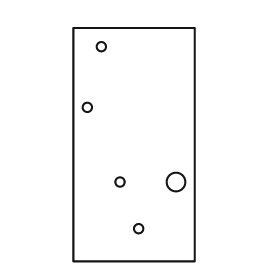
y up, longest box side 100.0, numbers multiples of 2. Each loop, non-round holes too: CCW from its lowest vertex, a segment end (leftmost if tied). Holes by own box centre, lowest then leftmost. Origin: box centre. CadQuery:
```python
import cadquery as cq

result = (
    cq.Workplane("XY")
    .moveTo(-26.0, -50.0)
    .lineTo(26.0, -50.0)
    .lineTo(26.0, 50.0)
    .lineTo(-26.0, 50.0)
    .close()
    .moveTo(2.0, -36.0)
    .circle(2.0)
    .moveTo(-6.0, -16.0)
    .circle(2.0)
    .moveTo(18.0, -16.0)
    .circle(4.0)
    .moveTo(-20.0, 16.0)
    .circle(2.0)
    .moveTo(-14.0, 42.0)
    .circle(2.0)
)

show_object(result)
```